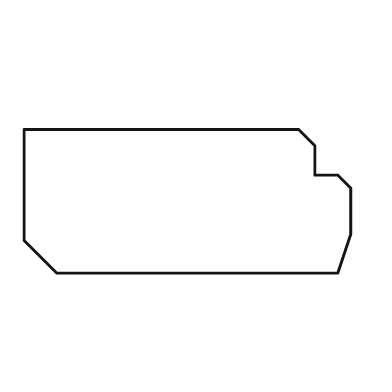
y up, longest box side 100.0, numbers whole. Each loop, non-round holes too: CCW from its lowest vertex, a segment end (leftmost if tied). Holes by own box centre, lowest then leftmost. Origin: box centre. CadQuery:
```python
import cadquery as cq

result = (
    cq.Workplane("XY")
    .moveTo(-40.0, -22.0)
    .lineTo(46.0, -22.0)
    .lineTo(50.0, -10.0)
    .lineTo(50.0, 4.0)
    .lineTo(46.0, 8.0)
    .lineTo(39.0, 8.0)
    .lineTo(39.0, 17.0)
    .lineTo(34.0, 22.0)
    .lineTo(-50.0, 22.0)
    .lineTo(-50.0, -12.0)
    .close()
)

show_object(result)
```